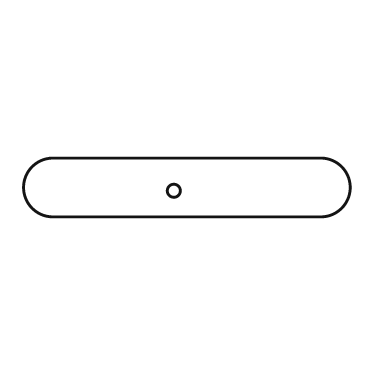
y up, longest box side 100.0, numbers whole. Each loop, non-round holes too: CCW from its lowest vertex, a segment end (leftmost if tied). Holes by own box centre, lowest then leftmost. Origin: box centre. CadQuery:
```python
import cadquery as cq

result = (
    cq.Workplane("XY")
    .moveTo(-41.0, -9.0)
    .lineTo(41.0, -9.0)
    .threePointArc((50.0, 0.0), (41.0, 9.0))
    .lineTo(-41.0, 9.0)
    .threePointArc((-50.0, 0.0), (-41.0, -9.0))
    .close()
    .moveTo(-4.0, -1.0)
    .circle(2.0)
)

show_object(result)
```